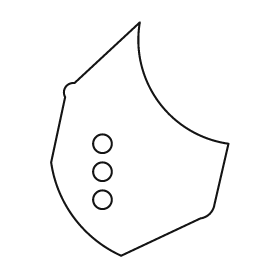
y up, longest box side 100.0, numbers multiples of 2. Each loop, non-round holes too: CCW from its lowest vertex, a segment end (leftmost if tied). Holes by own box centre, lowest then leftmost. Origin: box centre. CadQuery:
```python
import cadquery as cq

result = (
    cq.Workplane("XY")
    .moveTo(-8.0, -50.0)
    .lineTo(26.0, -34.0)
    .threePointArc((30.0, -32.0), (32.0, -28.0))
    .lineTo(38.0, -2.0)
    .threePointArc((8.0, 16.0), (0.0, 50.0))
    .lineTo(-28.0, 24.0)
    .threePointArc((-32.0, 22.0), (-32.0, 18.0))
    .lineTo(-38.0, -10.0)
    .threePointArc((-28.0, -34.0), (-8.0, -50.0))
    .close()
    .moveTo(-16.0, -26.0)
    .circle(4.0)
    .moveTo(-16.0, -14.0)
    .circle(4.0)
    .moveTo(-16.0, -2.0)
    .circle(4.0)
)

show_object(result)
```